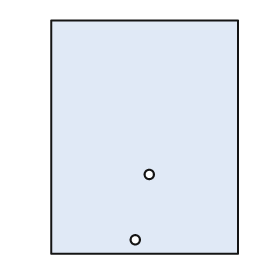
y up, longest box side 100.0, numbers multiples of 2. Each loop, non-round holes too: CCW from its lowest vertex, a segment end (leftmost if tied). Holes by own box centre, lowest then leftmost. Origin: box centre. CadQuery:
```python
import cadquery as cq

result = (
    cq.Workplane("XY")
    .moveTo(-40.0, -50.0)
    .lineTo(40.0, -50.0)
    .lineTo(40.0, 50.0)
    .lineTo(-40.0, 50.0)
    .close()
    .moveTo(-4.0, -44.0)
    .circle(2.0)
    .moveTo(2.0, -16.0)
    .circle(2.0)
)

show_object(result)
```